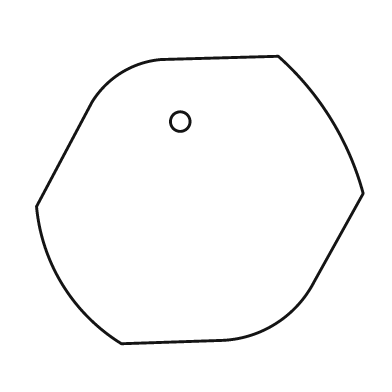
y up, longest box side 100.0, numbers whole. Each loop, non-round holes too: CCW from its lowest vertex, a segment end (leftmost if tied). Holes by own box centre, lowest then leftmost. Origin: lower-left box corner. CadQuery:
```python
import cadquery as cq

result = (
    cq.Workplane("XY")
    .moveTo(26.0, 0.0)
    .lineTo(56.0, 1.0)
    .threePointArc((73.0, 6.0), (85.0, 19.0))
    .lineTo(100.0, 46.0)
    .threePointArc((90.0, 69.0), (74.0, 88.0))
    .lineTo(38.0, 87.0)
    .threePointArc((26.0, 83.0), (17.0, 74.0))
    .lineTo(0.0, 42.0)
    .threePointArc((8.0, 18.0), (26.0, 0.0))
    .close()
    .moveTo(44.0, 68.0)
    .circle(3.0)
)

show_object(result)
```